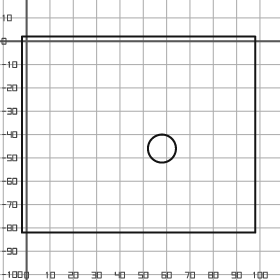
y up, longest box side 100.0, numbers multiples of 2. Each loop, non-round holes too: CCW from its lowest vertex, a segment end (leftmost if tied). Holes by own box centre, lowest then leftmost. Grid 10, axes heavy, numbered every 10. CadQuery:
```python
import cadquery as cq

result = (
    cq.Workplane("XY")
    .moveTo(-2.0, -82.0)
    .lineTo(98.0, -82.0)
    .lineTo(98.0, 2.0)
    .lineTo(-2.0, 2.0)
    .close()
    .moveTo(58.0, -46.0)
    .circle(6.0)
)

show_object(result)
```